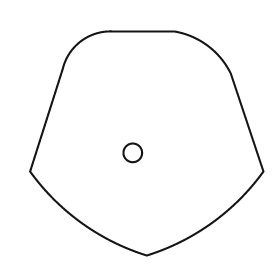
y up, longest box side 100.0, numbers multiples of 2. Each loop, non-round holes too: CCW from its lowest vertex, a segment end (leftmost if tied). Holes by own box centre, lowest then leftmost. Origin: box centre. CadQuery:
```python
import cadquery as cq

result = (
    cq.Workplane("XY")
    .moveTo(0.0, -48.0)
    .threePointArc((28.0, -34.0), (50.0, -12.0))
    .lineTo(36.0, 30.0)
    .threePointArc((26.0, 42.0), (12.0, 48.0))
    .lineTo(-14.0, 48.0)
    .threePointArc((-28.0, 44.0), (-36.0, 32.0))
    .lineTo(-50.0, -12.0)
    .threePointArc((-28.0, -34.0), (0.0, -48.0))
    .close()
    .moveTo(-6.0, -4.0)
    .circle(4.0)
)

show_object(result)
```